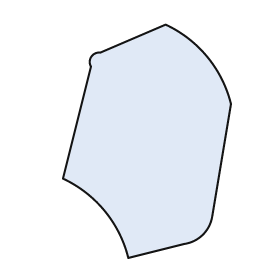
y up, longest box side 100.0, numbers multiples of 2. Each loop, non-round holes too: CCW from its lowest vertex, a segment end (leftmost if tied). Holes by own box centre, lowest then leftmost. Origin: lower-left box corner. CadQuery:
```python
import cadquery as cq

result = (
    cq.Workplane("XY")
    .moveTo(28.0, 0.0)
    .lineTo(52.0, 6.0)
    .threePointArc((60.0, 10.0), (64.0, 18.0))
    .lineTo(72.0, 66.0)
    .threePointArc((62.0, 86.0), (44.0, 100.0))
    .lineTo(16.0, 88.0)
    .threePointArc((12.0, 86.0), (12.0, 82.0))
    .lineTo(0.0, 34.0)
    .threePointArc((18.0, 20.0), (28.0, 0.0))
    .close()
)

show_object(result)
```